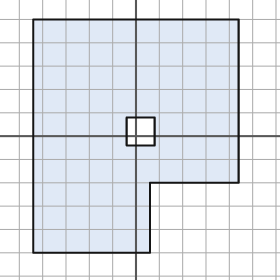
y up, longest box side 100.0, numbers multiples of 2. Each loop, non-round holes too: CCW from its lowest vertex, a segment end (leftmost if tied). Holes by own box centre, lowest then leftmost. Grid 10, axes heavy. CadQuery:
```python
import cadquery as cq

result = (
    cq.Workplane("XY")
    .moveTo(-44.0, -50.0)
    .lineTo(6.0, -50.0)
    .lineTo(6.0, -20.0)
    .lineTo(44.0, -20.0)
    .lineTo(44.0, 50.0)
    .lineTo(-44.0, 50.0)
    .close()
    .moveTo(-4.0, -4.0)
    .lineTo(8.0, -4.0)
    .lineTo(8.0, 8.0)
    .lineTo(-4.0, 8.0)
    .close()
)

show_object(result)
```